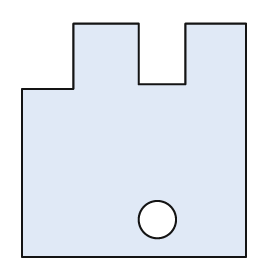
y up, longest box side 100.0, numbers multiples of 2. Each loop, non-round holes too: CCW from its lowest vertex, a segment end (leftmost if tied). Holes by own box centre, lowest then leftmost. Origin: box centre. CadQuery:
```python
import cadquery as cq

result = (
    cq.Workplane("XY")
    .moveTo(-48.0, -50.0)
    .lineTo(48.0, -50.0)
    .lineTo(48.0, 50.0)
    .lineTo(22.0, 50.0)
    .lineTo(22.0, 24.0)
    .lineTo(2.0, 24.0)
    .lineTo(2.0, 50.0)
    .lineTo(-26.0, 50.0)
    .lineTo(-26.0, 22.0)
    .lineTo(-48.0, 22.0)
    .close()
    .moveTo(10.0, -34.0)
    .circle(8.0)
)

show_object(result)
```